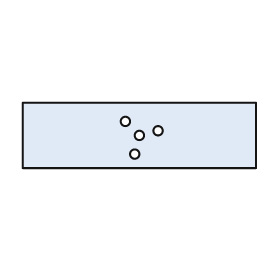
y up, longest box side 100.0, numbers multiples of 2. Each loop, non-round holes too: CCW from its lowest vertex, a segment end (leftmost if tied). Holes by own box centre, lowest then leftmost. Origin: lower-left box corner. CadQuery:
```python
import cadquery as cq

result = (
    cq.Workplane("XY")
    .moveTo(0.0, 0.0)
    .lineTo(100.0, 0.0)
    .lineTo(100.0, 28.0)
    .lineTo(0.0, 28.0)
    .close()
    .moveTo(48.0, 6.0)
    .circle(2.0)
    .moveTo(50.0, 14.0)
    .circle(2.0)
    .moveTo(58.0, 16.0)
    .circle(2.0)
    .moveTo(44.0, 20.0)
    .circle(2.0)
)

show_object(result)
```